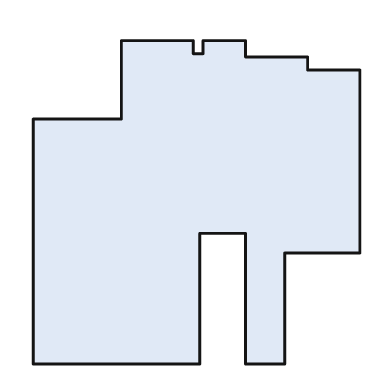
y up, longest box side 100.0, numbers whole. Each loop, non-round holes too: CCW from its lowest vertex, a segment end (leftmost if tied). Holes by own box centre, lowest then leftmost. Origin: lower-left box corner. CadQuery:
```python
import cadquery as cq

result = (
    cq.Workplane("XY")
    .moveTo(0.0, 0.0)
    .lineTo(51.0, 0.0)
    .lineTo(51.0, 40.0)
    .lineTo(65.0, 40.0)
    .lineTo(65.0, 0.0)
    .lineTo(77.0, 0.0)
    .lineTo(77.0, 34.0)
    .lineTo(100.0, 34.0)
    .lineTo(100.0, 90.0)
    .lineTo(84.0, 90.0)
    .lineTo(84.0, 94.0)
    .lineTo(65.0, 94.0)
    .lineTo(65.0, 99.0)
    .lineTo(52.0, 99.0)
    .lineTo(52.0, 95.0)
    .lineTo(49.0, 95.0)
    .lineTo(49.0, 99.0)
    .lineTo(27.0, 99.0)
    .lineTo(27.0, 75.0)
    .lineTo(0.0, 75.0)
    .close()
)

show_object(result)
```